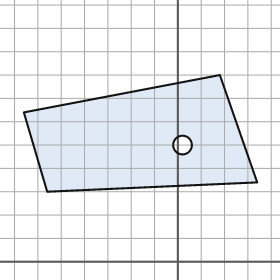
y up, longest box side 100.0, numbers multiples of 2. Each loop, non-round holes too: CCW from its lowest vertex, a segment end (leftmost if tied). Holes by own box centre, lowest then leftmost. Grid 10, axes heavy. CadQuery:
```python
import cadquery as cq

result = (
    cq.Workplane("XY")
    .moveTo(-56.0, 30.0)
    .lineTo(34.0, 34.0)
    .lineTo(18.0, 80.0)
    .lineTo(-66.0, 64.0)
    .close()
    .moveTo(2.0, 50.0)
    .circle(4.0)
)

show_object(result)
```